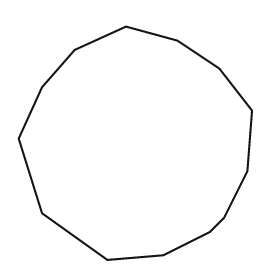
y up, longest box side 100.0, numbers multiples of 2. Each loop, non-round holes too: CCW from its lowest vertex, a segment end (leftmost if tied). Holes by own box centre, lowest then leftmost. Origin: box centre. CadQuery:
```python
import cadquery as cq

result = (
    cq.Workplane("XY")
    .moveTo(-12.0, -50.0)
    .lineTo(12.0, -48.0)
    .lineTo(32.0, -38.0)
    .lineTo(38.0, -32.0)
    .lineTo(48.0, -12.0)
    .lineTo(50.0, 14.0)
    .lineTo(36.0, 32.0)
    .lineTo(18.0, 44.0)
    .lineTo(-4.0, 50.0)
    .lineTo(-26.0, 40.0)
    .lineTo(-40.0, 24.0)
    .lineTo(-50.0, 2.0)
    .lineTo(-40.0, -30.0)
    .close()
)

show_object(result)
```